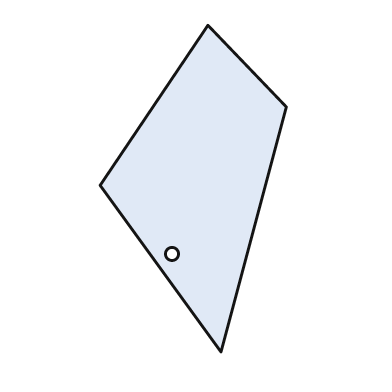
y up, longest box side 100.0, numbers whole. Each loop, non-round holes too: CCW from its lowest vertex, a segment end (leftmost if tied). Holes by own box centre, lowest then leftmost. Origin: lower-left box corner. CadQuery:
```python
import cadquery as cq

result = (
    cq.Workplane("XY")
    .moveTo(37.0, 0.0)
    .lineTo(57.0, 75.0)
    .lineTo(33.0, 100.0)
    .lineTo(0.0, 51.0)
    .close()
    .moveTo(22.0, 30.0)
    .circle(2.0)
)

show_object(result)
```